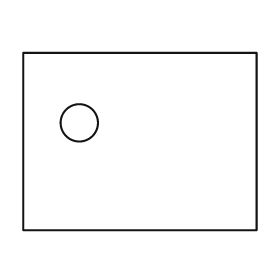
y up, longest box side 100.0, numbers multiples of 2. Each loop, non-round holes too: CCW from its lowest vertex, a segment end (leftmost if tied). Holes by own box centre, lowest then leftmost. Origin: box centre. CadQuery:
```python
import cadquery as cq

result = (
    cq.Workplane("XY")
    .moveTo(-50.0, -38.0)
    .lineTo(50.0, -38.0)
    .lineTo(50.0, 38.0)
    .lineTo(-50.0, 38.0)
    .close()
    .moveTo(-26.0, 8.0)
    .circle(8.0)
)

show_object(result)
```